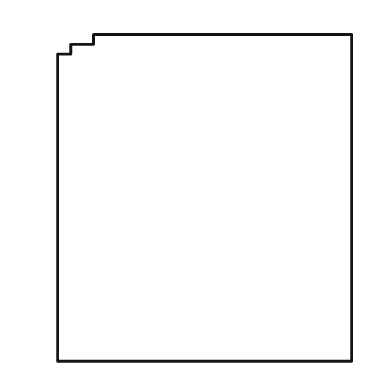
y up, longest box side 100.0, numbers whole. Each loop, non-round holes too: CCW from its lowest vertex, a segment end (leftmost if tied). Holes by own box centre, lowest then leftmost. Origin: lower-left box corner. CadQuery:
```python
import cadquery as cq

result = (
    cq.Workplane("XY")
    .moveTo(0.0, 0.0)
    .lineTo(90.0, 0.0)
    .lineTo(90.0, 100.0)
    .lineTo(11.0, 100.0)
    .lineTo(11.0, 97.0)
    .lineTo(4.0, 97.0)
    .lineTo(4.0, 94.0)
    .lineTo(0.0, 94.0)
    .close()
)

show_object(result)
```